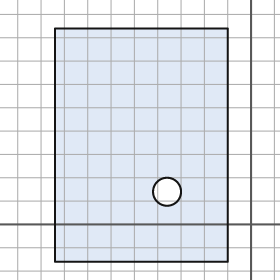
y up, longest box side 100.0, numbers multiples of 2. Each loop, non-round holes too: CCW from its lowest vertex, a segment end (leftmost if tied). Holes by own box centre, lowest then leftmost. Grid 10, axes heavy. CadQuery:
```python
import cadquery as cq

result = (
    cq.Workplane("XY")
    .moveTo(-84.0, -16.0)
    .lineTo(-10.0, -16.0)
    .lineTo(-10.0, 84.0)
    .lineTo(-84.0, 84.0)
    .close()
    .moveTo(-36.0, 14.0)
    .circle(6.0)
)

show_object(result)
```